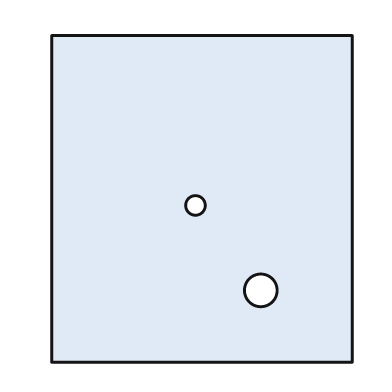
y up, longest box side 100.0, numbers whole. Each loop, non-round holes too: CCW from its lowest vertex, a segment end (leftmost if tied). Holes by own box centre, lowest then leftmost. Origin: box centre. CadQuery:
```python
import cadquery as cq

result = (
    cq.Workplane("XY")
    .moveTo(-46.0, -50.0)
    .lineTo(46.0, -50.0)
    .lineTo(46.0, 50.0)
    .lineTo(-46.0, 50.0)
    .close()
    .moveTo(18.0, -28.0)
    .circle(5.0)
    .moveTo(-2.0, -2.0)
    .circle(3.0)
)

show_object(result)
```